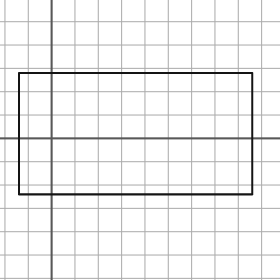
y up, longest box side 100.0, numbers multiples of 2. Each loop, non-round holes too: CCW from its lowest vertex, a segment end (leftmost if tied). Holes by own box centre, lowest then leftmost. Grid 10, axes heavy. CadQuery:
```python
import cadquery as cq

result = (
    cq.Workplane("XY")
    .moveTo(-14.0, -24.0)
    .lineTo(86.0, -24.0)
    .lineTo(86.0, 28.0)
    .lineTo(-14.0, 28.0)
    .close()
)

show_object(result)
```